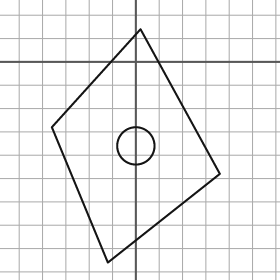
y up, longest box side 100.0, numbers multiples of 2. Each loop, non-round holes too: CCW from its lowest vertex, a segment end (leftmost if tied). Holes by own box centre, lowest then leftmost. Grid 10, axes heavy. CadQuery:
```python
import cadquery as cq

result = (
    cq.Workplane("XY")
    .moveTo(-12.0, -86.0)
    .lineTo(36.0, -48.0)
    .lineTo(2.0, 14.0)
    .lineTo(-36.0, -28.0)
    .close()
    .moveTo(0.0, -36.0)
    .circle(8.0)
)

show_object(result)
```